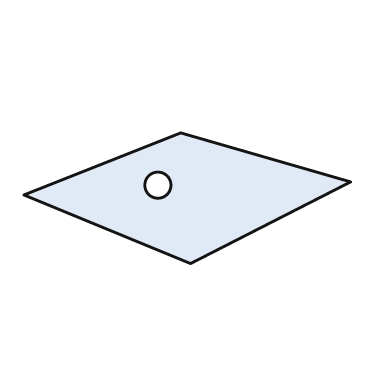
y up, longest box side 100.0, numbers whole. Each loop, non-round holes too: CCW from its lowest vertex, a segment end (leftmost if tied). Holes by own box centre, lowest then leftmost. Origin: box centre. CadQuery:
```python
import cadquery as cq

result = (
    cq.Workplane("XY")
    .moveTo(1.0, -20.0)
    .lineTo(50.0, 5.0)
    .lineTo(-2.0, 20.0)
    .lineTo(-50.0, 1.0)
    .close()
    .moveTo(-9.0, 4.0)
    .circle(4.0)
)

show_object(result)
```